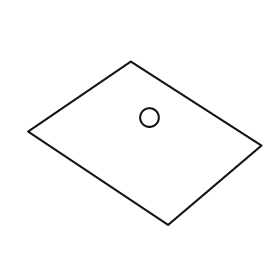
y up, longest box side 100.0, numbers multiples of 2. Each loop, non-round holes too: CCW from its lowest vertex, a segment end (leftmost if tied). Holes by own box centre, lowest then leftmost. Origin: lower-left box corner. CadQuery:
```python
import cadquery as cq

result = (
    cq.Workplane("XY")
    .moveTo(60.0, 0.0)
    .lineTo(100.0, 34.0)
    .lineTo(44.0, 70.0)
    .lineTo(0.0, 40.0)
    .close()
    .moveTo(52.0, 46.0)
    .circle(4.0)
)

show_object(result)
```